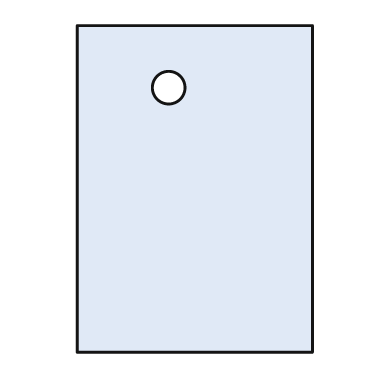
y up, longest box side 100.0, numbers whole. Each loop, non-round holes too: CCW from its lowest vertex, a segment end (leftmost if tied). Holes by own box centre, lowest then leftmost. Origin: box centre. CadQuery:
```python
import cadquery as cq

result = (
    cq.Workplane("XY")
    .moveTo(-36.0, -50.0)
    .lineTo(36.0, -50.0)
    .lineTo(36.0, 50.0)
    .lineTo(-36.0, 50.0)
    .close()
    .moveTo(-8.0, 31.0)
    .circle(5.0)
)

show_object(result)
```